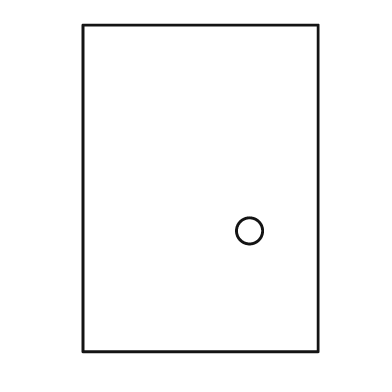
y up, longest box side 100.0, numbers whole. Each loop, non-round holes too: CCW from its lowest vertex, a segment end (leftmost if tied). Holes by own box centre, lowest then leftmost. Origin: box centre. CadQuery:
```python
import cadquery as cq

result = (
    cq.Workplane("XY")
    .moveTo(-36.0, -50.0)
    .lineTo(36.0, -50.0)
    .lineTo(36.0, 50.0)
    .lineTo(-36.0, 50.0)
    .close()
    .moveTo(15.0, -13.0)
    .circle(4.0)
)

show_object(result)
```